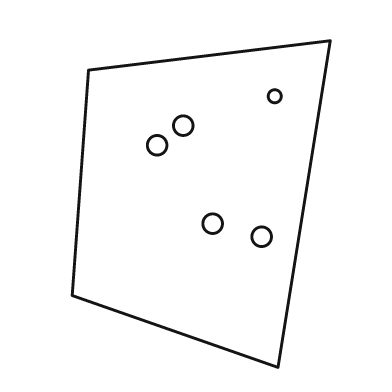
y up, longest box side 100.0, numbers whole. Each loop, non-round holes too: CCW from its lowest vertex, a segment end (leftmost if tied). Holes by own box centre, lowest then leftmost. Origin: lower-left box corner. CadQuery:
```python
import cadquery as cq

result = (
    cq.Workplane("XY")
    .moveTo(63.0, 0.0)
    .lineTo(79.0, 100.0)
    .lineTo(5.0, 91.0)
    .lineTo(0.0, 22.0)
    .close()
    .moveTo(58.0, 40.0)
    .circle(3.0)
    .moveTo(43.0, 44.0)
    .circle(3.0)
    .moveTo(26.0, 68.0)
    .circle(3.0)
    .moveTo(34.0, 74.0)
    .circle(3.0)
    .moveTo(62.0, 83.0)
    .circle(2.0)
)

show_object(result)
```